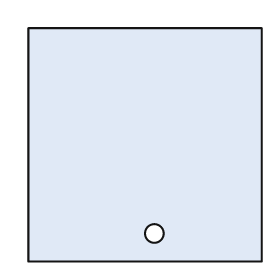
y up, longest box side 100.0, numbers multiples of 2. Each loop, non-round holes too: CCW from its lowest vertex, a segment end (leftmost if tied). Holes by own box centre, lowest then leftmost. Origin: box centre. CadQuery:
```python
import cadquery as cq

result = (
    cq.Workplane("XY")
    .moveTo(-50.0, -50.0)
    .lineTo(50.0, -50.0)
    .lineTo(50.0, 50.0)
    .lineTo(-50.0, 50.0)
    .close()
    .moveTo(4.0, -38.0)
    .circle(4.0)
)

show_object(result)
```